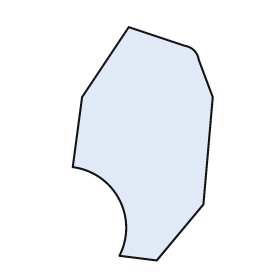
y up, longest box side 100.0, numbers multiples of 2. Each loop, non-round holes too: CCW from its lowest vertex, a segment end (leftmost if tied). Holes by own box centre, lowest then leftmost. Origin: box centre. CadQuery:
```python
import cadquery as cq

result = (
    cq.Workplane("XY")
    .moveTo(6.0, -50.0)
    .lineTo(26.0, -26.0)
    .lineTo(30.0, 20.0)
    .lineTo(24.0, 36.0)
    .threePointArc((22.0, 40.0), (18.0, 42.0))
    .lineTo(-6.0, 50.0)
    .lineTo(-26.0, 20.0)
    .lineTo(-30.0, -10.0)
    .threePointArc((-10.0, -24.0), (-10.0, -48.0))
    .close()
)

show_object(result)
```